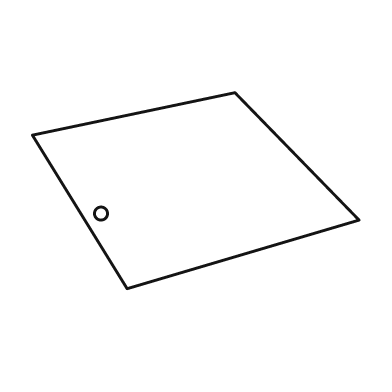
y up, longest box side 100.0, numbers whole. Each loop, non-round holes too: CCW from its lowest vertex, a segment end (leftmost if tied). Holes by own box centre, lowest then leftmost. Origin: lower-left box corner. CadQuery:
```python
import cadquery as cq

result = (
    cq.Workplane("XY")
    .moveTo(29.0, 0.0)
    .lineTo(100.0, 21.0)
    .lineTo(62.0, 60.0)
    .lineTo(0.0, 47.0)
    .close()
    .moveTo(21.0, 23.0)
    .circle(2.0)
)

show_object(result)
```